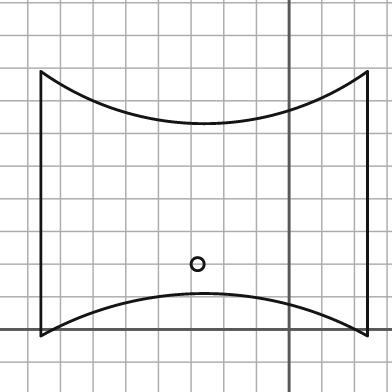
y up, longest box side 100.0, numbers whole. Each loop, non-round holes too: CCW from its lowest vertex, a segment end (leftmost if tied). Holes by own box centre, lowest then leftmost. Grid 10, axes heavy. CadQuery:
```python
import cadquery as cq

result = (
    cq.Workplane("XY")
    .moveTo(-76.0, -2.0)
    .threePointArc((-26.0, 11.0), (24.0, -2.0))
    .lineTo(24.0, 79.0)
    .threePointArc((-26.0, 63.0), (-76.0, 79.0))
    .close()
    .moveTo(-28.0, 20.0)
    .circle(2.0)
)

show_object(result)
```